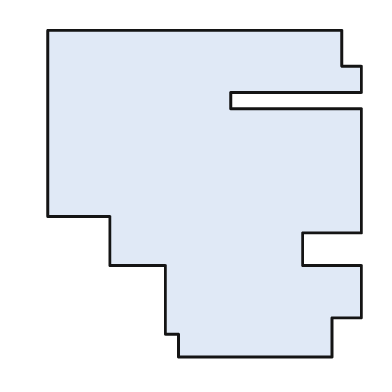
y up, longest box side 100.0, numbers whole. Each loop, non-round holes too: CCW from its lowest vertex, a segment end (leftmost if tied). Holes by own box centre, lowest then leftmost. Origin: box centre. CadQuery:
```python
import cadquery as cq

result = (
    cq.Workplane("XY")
    .moveTo(-8.0, -50.0)
    .lineTo(39.0, -50.0)
    .lineTo(39.0, -38.0)
    .lineTo(48.0, -38.0)
    .lineTo(48.0, -22.0)
    .lineTo(30.0, -22.0)
    .lineTo(30.0, -12.0)
    .lineTo(48.0, -12.0)
    .lineTo(48.0, 26.0)
    .lineTo(8.0, 26.0)
    .lineTo(8.0, 31.0)
    .lineTo(48.0, 31.0)
    .lineTo(48.0, 39.0)
    .lineTo(42.0, 39.0)
    .lineTo(42.0, 50.0)
    .lineTo(-48.0, 50.0)
    .lineTo(-48.0, -7.0)
    .lineTo(-29.0, -7.0)
    .lineTo(-29.0, -22.0)
    .lineTo(-12.0, -22.0)
    .lineTo(-12.0, -43.0)
    .lineTo(-8.0, -43.0)
    .close()
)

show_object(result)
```